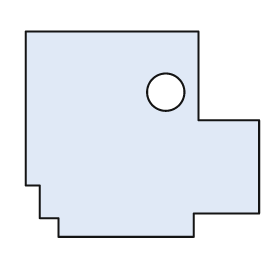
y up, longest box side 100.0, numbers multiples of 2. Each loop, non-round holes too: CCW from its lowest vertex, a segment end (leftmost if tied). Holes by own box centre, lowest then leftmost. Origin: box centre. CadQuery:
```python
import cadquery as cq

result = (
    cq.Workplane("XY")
    .moveTo(-36.0, -44.0)
    .lineTo(22.0, -44.0)
    .lineTo(22.0, -34.0)
    .lineTo(50.0, -34.0)
    .lineTo(50.0, 6.0)
    .lineTo(24.0, 6.0)
    .lineTo(24.0, 44.0)
    .lineTo(-50.0, 44.0)
    .lineTo(-50.0, -22.0)
    .lineTo(-44.0, -22.0)
    .lineTo(-44.0, -36.0)
    .lineTo(-36.0, -36.0)
    .close()
    .moveTo(10.0, 18.0)
    .circle(8.0)
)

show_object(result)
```